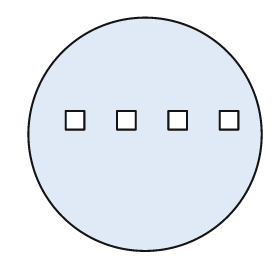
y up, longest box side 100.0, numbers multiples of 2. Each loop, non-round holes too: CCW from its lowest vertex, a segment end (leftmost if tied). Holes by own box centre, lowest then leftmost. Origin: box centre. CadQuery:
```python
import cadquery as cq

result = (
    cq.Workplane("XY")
    .moveTo(0.0, 0.0)
    .circle(50.0)
    .moveTo(-34.0, 2.0)
    .lineTo(-26.0, 2.0)
    .lineTo(-26.0, 10.0)
    .lineTo(-34.0, 10.0)
    .close()
    .moveTo(-12.0, 2.0)
    .lineTo(-4.0, 2.0)
    .lineTo(-4.0, 10.0)
    .lineTo(-12.0, 10.0)
    .close()
    .moveTo(10.0, 2.0)
    .lineTo(18.0, 2.0)
    .lineTo(18.0, 10.0)
    .lineTo(10.0, 10.0)
    .close()
    .moveTo(32.0, 2.0)
    .lineTo(40.0, 2.0)
    .lineTo(40.0, 10.0)
    .lineTo(32.0, 10.0)
    .close()
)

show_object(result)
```